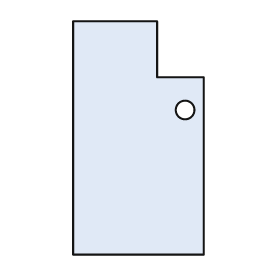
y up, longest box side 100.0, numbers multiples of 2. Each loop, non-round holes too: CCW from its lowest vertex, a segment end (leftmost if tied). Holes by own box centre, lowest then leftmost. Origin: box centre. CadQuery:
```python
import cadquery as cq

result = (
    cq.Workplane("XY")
    .moveTo(-28.0, -50.0)
    .lineTo(28.0, -50.0)
    .lineTo(28.0, 26.0)
    .lineTo(8.0, 26.0)
    .lineTo(8.0, 50.0)
    .lineTo(-28.0, 50.0)
    .close()
    .moveTo(20.0, 12.0)
    .circle(4.0)
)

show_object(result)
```